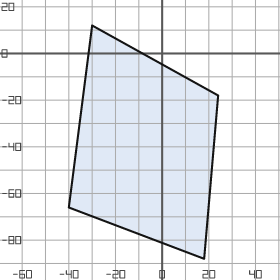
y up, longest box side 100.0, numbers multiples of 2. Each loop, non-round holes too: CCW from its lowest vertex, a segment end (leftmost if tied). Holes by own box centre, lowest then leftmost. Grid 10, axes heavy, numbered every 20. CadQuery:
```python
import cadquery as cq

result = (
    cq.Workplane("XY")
    .moveTo(18.0, -88.0)
    .lineTo(24.0, -18.0)
    .lineTo(-30.0, 12.0)
    .lineTo(-40.0, -66.0)
    .close()
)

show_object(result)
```